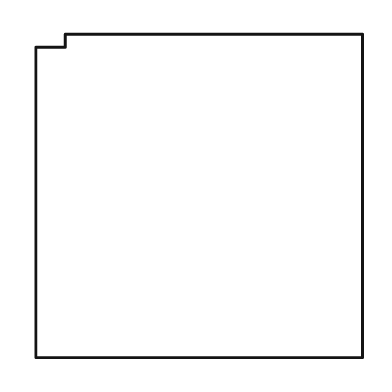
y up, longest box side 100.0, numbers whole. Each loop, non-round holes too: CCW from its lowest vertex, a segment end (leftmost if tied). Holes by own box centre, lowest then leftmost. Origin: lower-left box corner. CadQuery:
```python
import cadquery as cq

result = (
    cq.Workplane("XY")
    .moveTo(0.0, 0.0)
    .lineTo(100.0, 0.0)
    .lineTo(100.0, 99.0)
    .lineTo(9.0, 99.0)
    .lineTo(9.0, 95.0)
    .lineTo(0.0, 95.0)
    .close()
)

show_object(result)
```